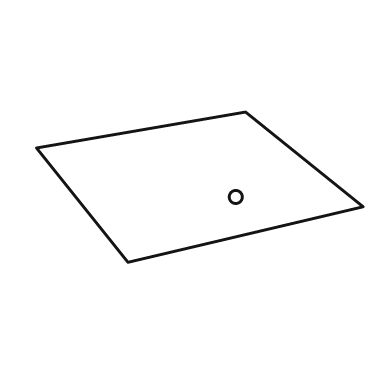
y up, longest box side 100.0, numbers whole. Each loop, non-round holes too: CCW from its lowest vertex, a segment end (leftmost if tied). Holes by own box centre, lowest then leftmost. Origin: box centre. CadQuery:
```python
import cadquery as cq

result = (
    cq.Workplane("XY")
    .moveTo(-22.0, -23.0)
    .lineTo(50.0, -6.0)
    .lineTo(14.0, 23.0)
    .lineTo(-50.0, 12.0)
    .close()
    .moveTo(11.0, -3.0)
    .circle(2.0)
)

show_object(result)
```